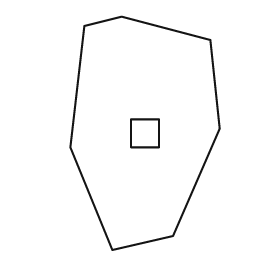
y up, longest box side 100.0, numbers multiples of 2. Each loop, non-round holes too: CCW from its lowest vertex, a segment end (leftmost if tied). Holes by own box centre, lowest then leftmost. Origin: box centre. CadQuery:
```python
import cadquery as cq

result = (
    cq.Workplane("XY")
    .moveTo(-14.0, -50.0)
    .lineTo(12.0, -44.0)
    .lineTo(32.0, 2.0)
    .lineTo(28.0, 40.0)
    .lineTo(-10.0, 50.0)
    .lineTo(-26.0, 46.0)
    .lineTo(-32.0, -6.0)
    .close()
    .moveTo(-6.0, -6.0)
    .lineTo(6.0, -6.0)
    .lineTo(6.0, 6.0)
    .lineTo(-6.0, 6.0)
    .close()
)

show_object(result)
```